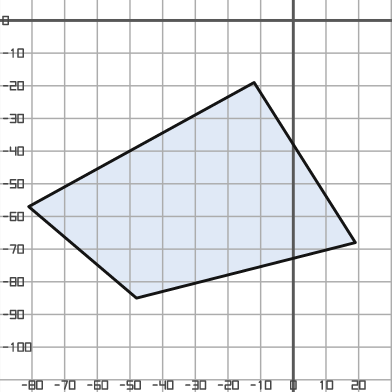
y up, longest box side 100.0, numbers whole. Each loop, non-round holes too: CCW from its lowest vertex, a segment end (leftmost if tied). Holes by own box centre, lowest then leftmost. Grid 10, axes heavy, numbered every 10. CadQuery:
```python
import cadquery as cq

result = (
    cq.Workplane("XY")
    .moveTo(-48.0, -85.0)
    .lineTo(19.0, -68.0)
    .lineTo(-12.0, -19.0)
    .lineTo(-81.0, -57.0)
    .close()
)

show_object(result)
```